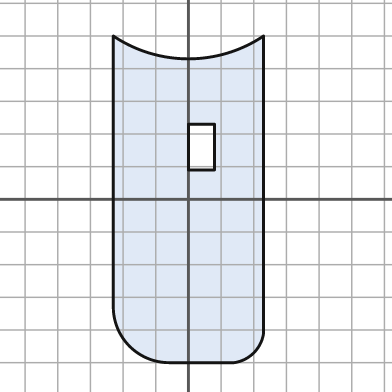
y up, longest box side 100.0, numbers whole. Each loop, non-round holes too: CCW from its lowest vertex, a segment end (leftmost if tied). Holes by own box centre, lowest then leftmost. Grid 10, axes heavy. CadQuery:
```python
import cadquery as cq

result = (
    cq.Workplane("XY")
    .moveTo(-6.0, -50.0)
    .lineTo(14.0, -50.0)
    .threePointArc((20.0, -47.0), (23.0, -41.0))
    .lineTo(23.0, 50.0)
    .threePointArc((0.0, 43.0), (-23.0, 50.0))
    .lineTo(-23.0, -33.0)
    .threePointArc((-18.0, -45.0), (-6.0, -50.0))
    .close()
    .moveTo(0.0, 9.0)
    .lineTo(8.0, 9.0)
    .lineTo(8.0, 23.0)
    .lineTo(0.0, 23.0)
    .close()
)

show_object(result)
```